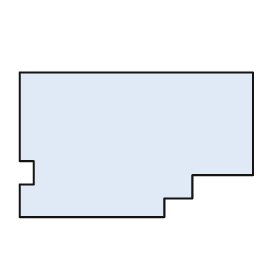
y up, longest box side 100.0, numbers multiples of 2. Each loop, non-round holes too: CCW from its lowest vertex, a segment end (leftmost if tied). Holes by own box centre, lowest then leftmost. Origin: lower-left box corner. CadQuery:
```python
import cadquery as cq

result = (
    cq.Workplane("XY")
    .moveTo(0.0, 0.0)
    .lineTo(62.0, 0.0)
    .lineTo(62.0, 8.0)
    .lineTo(74.0, 8.0)
    .lineTo(74.0, 18.0)
    .lineTo(100.0, 18.0)
    .lineTo(100.0, 62.0)
    .lineTo(0.0, 62.0)
    .lineTo(0.0, 24.0)
    .lineTo(6.0, 24.0)
    .lineTo(6.0, 14.0)
    .lineTo(0.0, 14.0)
    .close()
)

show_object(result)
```